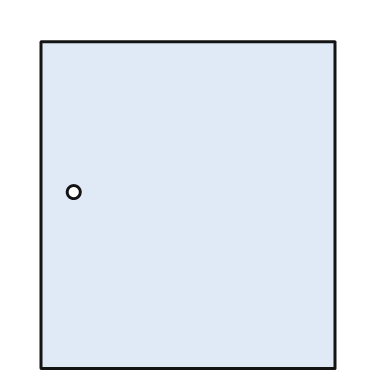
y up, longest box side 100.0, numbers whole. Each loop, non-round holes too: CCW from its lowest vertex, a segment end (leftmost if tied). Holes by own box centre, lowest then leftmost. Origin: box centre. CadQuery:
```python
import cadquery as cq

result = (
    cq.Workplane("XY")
    .moveTo(-45.0, -50.0)
    .lineTo(45.0, -50.0)
    .lineTo(45.0, 50.0)
    .lineTo(-45.0, 50.0)
    .close()
    .moveTo(-35.0, 4.0)
    .circle(2.0)
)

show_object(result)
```